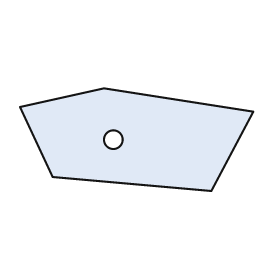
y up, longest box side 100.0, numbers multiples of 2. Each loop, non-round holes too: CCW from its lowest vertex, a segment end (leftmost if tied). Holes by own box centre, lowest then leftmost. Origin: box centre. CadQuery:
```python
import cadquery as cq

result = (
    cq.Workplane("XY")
    .moveTo(32.0, -22.0)
    .lineTo(50.0, 12.0)
    .lineTo(-14.0, 22.0)
    .lineTo(-50.0, 14.0)
    .lineTo(-36.0, -16.0)
    .close()
    .moveTo(-10.0, 0.0)
    .circle(4.0)
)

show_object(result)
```